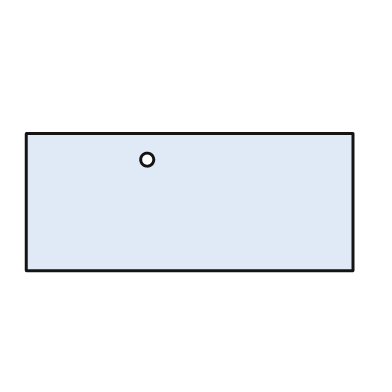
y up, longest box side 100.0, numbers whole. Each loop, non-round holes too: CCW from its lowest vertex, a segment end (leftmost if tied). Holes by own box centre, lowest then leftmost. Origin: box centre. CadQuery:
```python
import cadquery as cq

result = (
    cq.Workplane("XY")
    .moveTo(-50.0, -21.0)
    .lineTo(50.0, -21.0)
    .lineTo(50.0, 21.0)
    .lineTo(-50.0, 21.0)
    .close()
    .moveTo(-13.0, 13.0)
    .circle(2.0)
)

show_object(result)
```